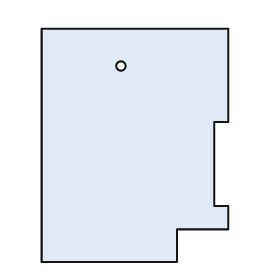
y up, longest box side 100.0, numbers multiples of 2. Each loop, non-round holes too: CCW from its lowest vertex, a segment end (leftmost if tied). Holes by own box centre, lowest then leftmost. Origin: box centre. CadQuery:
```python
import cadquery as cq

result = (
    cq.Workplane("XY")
    .moveTo(-40.0, -50.0)
    .lineTo(18.0, -50.0)
    .lineTo(18.0, -36.0)
    .lineTo(40.0, -36.0)
    .lineTo(40.0, -26.0)
    .lineTo(34.0, -26.0)
    .lineTo(34.0, 10.0)
    .lineTo(40.0, 10.0)
    .lineTo(40.0, 50.0)
    .lineTo(-40.0, 50.0)
    .close()
    .moveTo(-6.0, 34.0)
    .circle(2.0)
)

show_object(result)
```